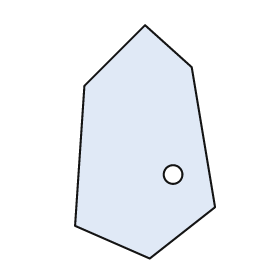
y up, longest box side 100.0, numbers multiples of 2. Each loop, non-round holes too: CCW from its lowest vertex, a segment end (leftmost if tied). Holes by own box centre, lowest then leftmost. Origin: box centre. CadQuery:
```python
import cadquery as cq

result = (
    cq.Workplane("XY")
    .moveTo(2.0, -50.0)
    .lineTo(30.0, -28.0)
    .lineTo(20.0, 32.0)
    .lineTo(0.0, 50.0)
    .lineTo(-26.0, 24.0)
    .lineTo(-30.0, -36.0)
    .close()
    .moveTo(12.0, -14.0)
    .circle(4.0)
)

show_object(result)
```